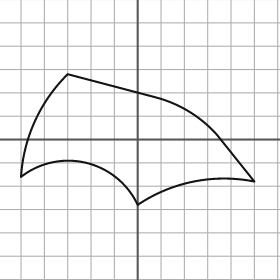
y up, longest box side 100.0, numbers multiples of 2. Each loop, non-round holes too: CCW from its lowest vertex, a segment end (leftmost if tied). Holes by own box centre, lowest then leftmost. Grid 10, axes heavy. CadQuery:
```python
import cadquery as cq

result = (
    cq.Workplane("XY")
    .moveTo(0.0, -28.0)
    .threePointArc((24.0, -18.0), (50.0, -18.0))
    .lineTo(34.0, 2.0)
    .threePointArc((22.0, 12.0), (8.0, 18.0))
    .lineTo(-30.0, 28.0)
    .threePointArc((-44.0, 8.0), (-50.0, -16.0))
    .threePointArc((-22.0, -10.0), (0.0, -28.0))
    .close()
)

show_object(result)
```